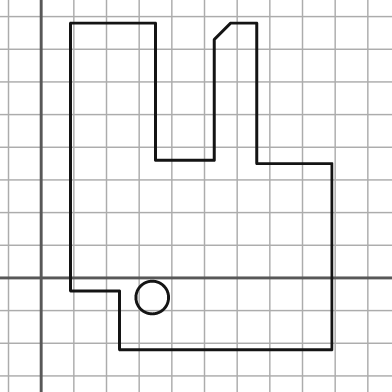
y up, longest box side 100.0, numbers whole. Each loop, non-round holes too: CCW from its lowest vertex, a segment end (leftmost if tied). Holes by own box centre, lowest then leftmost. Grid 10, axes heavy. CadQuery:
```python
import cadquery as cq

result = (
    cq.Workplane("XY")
    .moveTo(24.0, -22.0)
    .lineTo(89.0, -22.0)
    .lineTo(89.0, 35.0)
    .lineTo(66.0, 35.0)
    .lineTo(66.0, 78.0)
    .lineTo(58.0, 78.0)
    .lineTo(53.0, 73.0)
    .lineTo(53.0, 36.0)
    .lineTo(35.0, 36.0)
    .lineTo(35.0, 78.0)
    .lineTo(9.0, 78.0)
    .lineTo(9.0, -4.0)
    .lineTo(24.0, -4.0)
    .close()
    .moveTo(34.0, -6.0)
    .circle(5.0)
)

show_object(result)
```